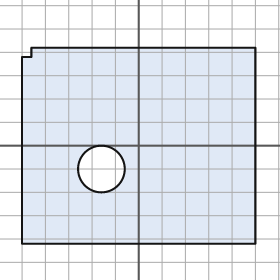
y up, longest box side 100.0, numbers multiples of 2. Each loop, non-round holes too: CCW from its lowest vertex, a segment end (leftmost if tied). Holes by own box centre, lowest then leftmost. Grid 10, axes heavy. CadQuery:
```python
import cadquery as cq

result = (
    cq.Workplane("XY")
    .moveTo(-50.0, -42.0)
    .lineTo(50.0, -42.0)
    .lineTo(50.0, 42.0)
    .lineTo(-46.0, 42.0)
    .lineTo(-46.0, 38.0)
    .lineTo(-50.0, 38.0)
    .close()
    .moveTo(-16.0, -10.0)
    .circle(10.0)
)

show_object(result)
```